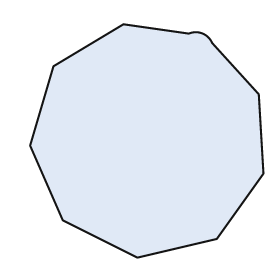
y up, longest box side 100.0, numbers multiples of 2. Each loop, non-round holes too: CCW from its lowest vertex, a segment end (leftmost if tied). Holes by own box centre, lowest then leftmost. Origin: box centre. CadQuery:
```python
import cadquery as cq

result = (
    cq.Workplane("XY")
    .moveTo(-4.0, -50.0)
    .lineTo(30.0, -42.0)
    .lineTo(50.0, -14.0)
    .lineTo(48.0, 20.0)
    .lineTo(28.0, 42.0)
    .threePointArc((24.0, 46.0), (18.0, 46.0))
    .lineTo(-10.0, 50.0)
    .lineTo(-40.0, 32.0)
    .lineTo(-50.0, -2.0)
    .lineTo(-36.0, -34.0)
    .close()
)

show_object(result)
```